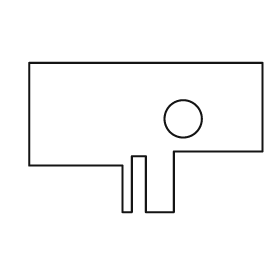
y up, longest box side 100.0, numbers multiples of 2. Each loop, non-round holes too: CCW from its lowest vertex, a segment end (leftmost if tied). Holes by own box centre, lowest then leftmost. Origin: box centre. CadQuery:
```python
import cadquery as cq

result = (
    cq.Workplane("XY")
    .moveTo(-10.0, -32.0)
    .lineTo(-6.0, -32.0)
    .lineTo(-6.0, -8.0)
    .lineTo(0.0, -8.0)
    .lineTo(0.0, -32.0)
    .lineTo(12.0, -32.0)
    .lineTo(12.0, -6.0)
    .lineTo(50.0, -6.0)
    .lineTo(50.0, 32.0)
    .lineTo(-50.0, 32.0)
    .lineTo(-50.0, -12.0)
    .lineTo(-10.0, -12.0)
    .close()
    .moveTo(16.0, 8.0)
    .circle(8.0)
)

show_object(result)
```